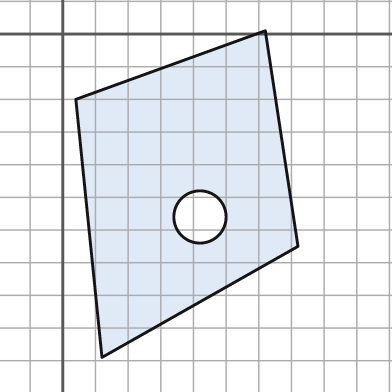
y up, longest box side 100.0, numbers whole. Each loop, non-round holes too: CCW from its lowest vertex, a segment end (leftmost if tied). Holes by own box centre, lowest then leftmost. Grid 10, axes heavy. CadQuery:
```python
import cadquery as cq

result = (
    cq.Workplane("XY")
    .moveTo(12.0, -99.0)
    .lineTo(72.0, -65.0)
    .lineTo(62.0, 1.0)
    .lineTo(4.0, -20.0)
    .close()
    .moveTo(42.0, -56.0)
    .circle(8.0)
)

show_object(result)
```